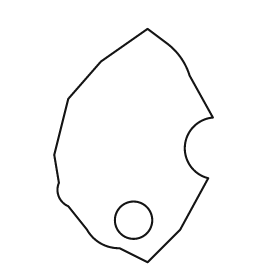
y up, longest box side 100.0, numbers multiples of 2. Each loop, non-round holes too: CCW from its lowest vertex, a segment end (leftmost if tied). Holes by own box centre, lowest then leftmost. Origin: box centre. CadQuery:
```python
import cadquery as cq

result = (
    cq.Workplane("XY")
    .moveTo(6.0, -50.0)
    .lineTo(20.0, -36.0)
    .lineTo(32.0, -14.0)
    .threePointArc((22.0, 0.0), (34.0, 12.0))
    .lineTo(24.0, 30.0)
    .threePointArc((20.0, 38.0), (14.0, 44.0))
    .lineTo(6.0, 50.0)
    .lineTo(-14.0, 36.0)
    .lineTo(-28.0, 20.0)
    .lineTo(-34.0, -4.0)
    .lineTo(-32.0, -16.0)
    .threePointArc((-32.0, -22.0), (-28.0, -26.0))
    .lineTo(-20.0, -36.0)
    .threePointArc((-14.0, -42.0), (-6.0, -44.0))
    .close()
    .moveTo(0.0, -32.0)
    .circle(8.0)
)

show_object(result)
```